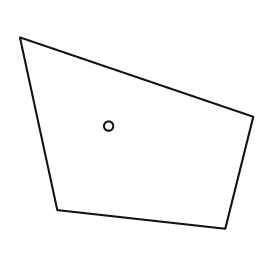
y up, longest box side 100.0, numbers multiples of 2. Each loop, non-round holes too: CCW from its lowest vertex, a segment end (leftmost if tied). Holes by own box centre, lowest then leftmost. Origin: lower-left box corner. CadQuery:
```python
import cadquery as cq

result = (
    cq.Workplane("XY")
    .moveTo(88.0, 0.0)
    .lineTo(100.0, 48.0)
    .lineTo(0.0, 82.0)
    .lineTo(16.0, 8.0)
    .close()
    .moveTo(38.0, 44.0)
    .circle(2.0)
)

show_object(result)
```